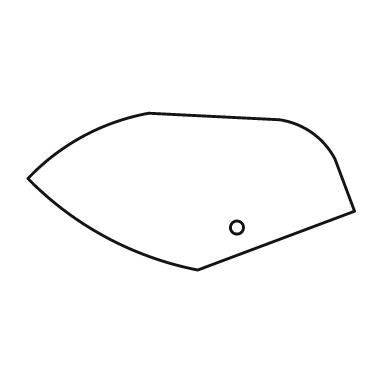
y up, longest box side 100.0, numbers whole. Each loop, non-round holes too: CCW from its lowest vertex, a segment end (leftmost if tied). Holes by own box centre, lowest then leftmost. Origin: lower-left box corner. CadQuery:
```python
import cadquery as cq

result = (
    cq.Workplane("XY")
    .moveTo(52.0, 0.0)
    .lineTo(100.0, 18.0)
    .lineTo(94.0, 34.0)
    .threePointArc((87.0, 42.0), (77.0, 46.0))
    .lineTo(37.0, 48.0)
    .threePointArc((17.0, 41.0), (0.0, 28.0))
    .threePointArc((24.0, 10.0), (52.0, 0.0))
    .close()
    .moveTo(64.0, 13.0)
    .circle(2.0)
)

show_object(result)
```